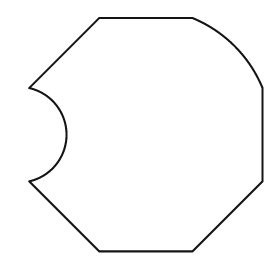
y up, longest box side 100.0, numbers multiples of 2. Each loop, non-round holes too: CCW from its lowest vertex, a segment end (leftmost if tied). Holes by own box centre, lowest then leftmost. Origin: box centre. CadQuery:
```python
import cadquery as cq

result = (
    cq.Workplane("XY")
    .moveTo(-20.0, -50.0)
    .lineTo(20.0, -50.0)
    .lineTo(50.0, -20.0)
    .lineTo(50.0, 20.0)
    .threePointArc((38.0, 38.0), (20.0, 50.0))
    .lineTo(-20.0, 50.0)
    .lineTo(-50.0, 20.0)
    .threePointArc((-34.0, 0.0), (-50.0, -20.0))
    .close()
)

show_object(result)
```